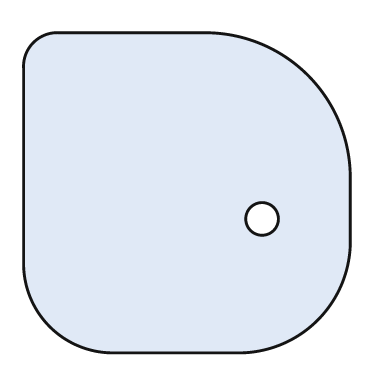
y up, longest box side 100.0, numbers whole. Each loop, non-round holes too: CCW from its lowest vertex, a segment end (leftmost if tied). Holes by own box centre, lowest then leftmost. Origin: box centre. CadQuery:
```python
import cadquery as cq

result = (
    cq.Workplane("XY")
    .moveTo(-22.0, -49.0)
    .lineTo(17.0, -49.0)
    .threePointArc((40.0, -39.0), (50.0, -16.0))
    .lineTo(50.0, 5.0)
    .threePointArc((37.0, 36.0), (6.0, 49.0))
    .lineTo(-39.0, 49.0)
    .threePointArc((-47.0, 46.0), (-50.0, 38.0))
    .lineTo(-50.0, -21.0)
    .threePointArc((-42.0, -41.0), (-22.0, -49.0))
    .close()
    .moveTo(23.0, -8.0)
    .circle(5.0)
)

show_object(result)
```